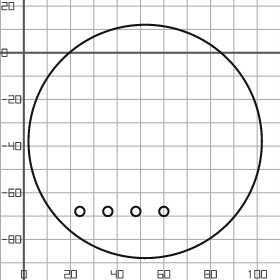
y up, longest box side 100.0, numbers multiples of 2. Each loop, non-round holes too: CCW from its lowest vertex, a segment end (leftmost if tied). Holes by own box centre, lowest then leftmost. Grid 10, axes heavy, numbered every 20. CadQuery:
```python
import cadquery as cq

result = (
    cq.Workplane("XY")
    .moveTo(52.0, -38.0)
    .circle(50.0)
    .moveTo(24.0, -68.0)
    .circle(2.0)
    .moveTo(36.0, -68.0)
    .circle(2.0)
    .moveTo(48.0, -68.0)
    .circle(2.0)
    .moveTo(60.0, -68.0)
    .circle(2.0)
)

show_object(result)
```